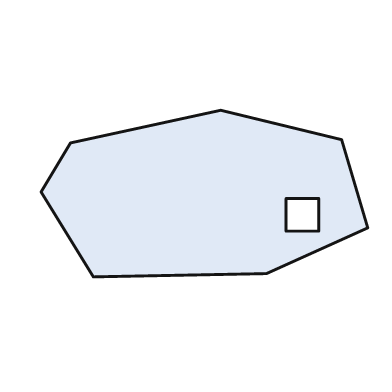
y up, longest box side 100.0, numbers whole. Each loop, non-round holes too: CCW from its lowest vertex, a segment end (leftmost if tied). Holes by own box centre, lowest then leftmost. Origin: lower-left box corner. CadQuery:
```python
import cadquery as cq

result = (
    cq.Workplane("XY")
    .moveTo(16.0, 0.0)
    .lineTo(69.0, 1.0)
    .lineTo(100.0, 15.0)
    .lineTo(92.0, 42.0)
    .lineTo(55.0, 51.0)
    .lineTo(9.0, 41.0)
    .lineTo(0.0, 26.0)
    .close()
    .moveTo(75.0, 14.0)
    .lineTo(85.0, 14.0)
    .lineTo(85.0, 24.0)
    .lineTo(75.0, 24.0)
    .close()
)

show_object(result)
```